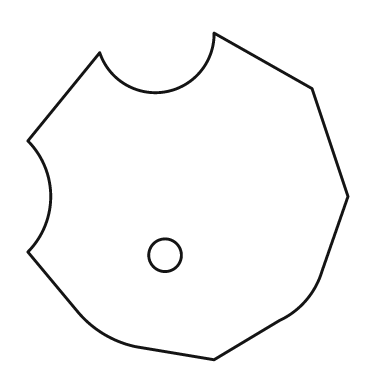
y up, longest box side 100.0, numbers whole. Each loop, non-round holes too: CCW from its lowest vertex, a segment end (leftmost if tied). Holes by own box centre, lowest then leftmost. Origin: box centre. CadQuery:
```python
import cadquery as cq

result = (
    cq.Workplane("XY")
    .moveTo(8.0, -50.0)
    .lineTo(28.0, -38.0)
    .threePointArc((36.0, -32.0), (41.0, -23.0))
    .lineTo(49.0, 0.0)
    .lineTo(38.0, 33.0)
    .lineTo(8.0, 50.0)
    .threePointArc((-7.0, 32.0), (-27.0, 44.0))
    .lineTo(-49.0, 17.0)
    .threePointArc((-42.0, 0.0), (-49.0, -17.0))
    .lineTo(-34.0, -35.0)
    .threePointArc((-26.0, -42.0), (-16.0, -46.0))
    .close()
    .moveTo(-7.0, -18.0)
    .circle(5.0)
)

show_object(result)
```